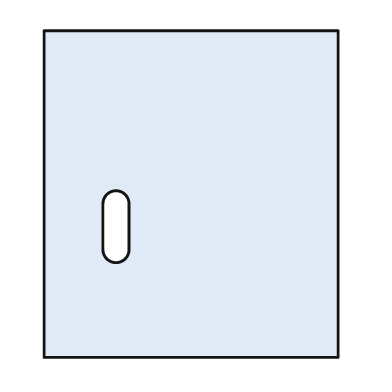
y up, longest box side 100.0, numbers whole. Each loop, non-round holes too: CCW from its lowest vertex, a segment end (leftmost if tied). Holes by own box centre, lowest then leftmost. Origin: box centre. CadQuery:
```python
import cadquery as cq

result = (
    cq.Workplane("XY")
    .moveTo(-45.0, -50.0)
    .lineTo(45.0, -50.0)
    .lineTo(45.0, 50.0)
    .lineTo(-45.0, 50.0)
    .close()
    .moveTo(-27.0, -17.0)
    .threePointArc((-23.0, -21.0), (-19.0, -17.0))
    .lineTo(-19.0, -3.0)
    .threePointArc((-23.0, 1.0), (-27.0, -3.0))
    .close()
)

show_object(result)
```